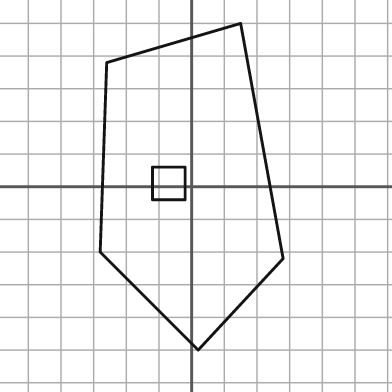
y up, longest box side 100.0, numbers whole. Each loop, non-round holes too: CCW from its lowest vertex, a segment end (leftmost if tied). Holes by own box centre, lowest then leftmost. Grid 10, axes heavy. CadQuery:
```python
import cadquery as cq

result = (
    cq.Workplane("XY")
    .moveTo(2.0, -50.0)
    .lineTo(28.0, -22.0)
    .lineTo(15.0, 50.0)
    .lineTo(-26.0, 38.0)
    .lineTo(-28.0, -20.0)
    .close()
    .moveTo(-12.0, -4.0)
    .lineTo(-2.0, -4.0)
    .lineTo(-2.0, 6.0)
    .lineTo(-12.0, 6.0)
    .close()
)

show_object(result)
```